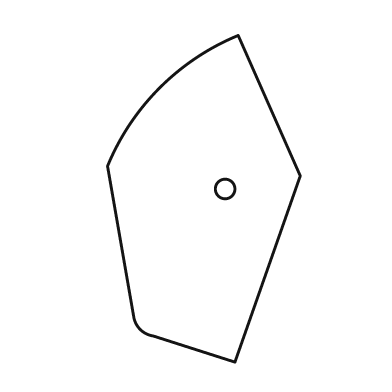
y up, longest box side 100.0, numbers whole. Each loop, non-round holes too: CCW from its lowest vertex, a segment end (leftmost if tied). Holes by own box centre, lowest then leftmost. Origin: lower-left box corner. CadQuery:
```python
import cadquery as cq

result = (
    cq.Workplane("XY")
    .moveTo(39.0, 0.0)
    .lineTo(59.0, 57.0)
    .lineTo(40.0, 100.0)
    .threePointArc((16.0, 84.0), (0.0, 60.0))
    .lineTo(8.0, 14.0)
    .threePointArc((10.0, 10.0), (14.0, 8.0))
    .close()
    .moveTo(36.0, 53.0)
    .circle(3.0)
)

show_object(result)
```